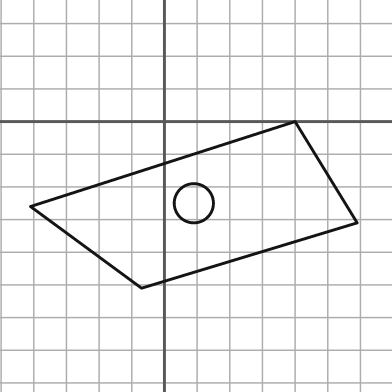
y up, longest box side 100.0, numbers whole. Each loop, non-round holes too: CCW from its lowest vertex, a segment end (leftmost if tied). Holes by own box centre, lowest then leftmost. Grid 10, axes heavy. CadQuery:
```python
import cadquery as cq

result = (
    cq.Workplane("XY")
    .moveTo(-7.0, -51.0)
    .lineTo(59.0, -31.0)
    .lineTo(40.0, 0.0)
    .lineTo(-41.0, -26.0)
    .close()
    .moveTo(9.0, -25.0)
    .circle(6.0)
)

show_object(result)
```